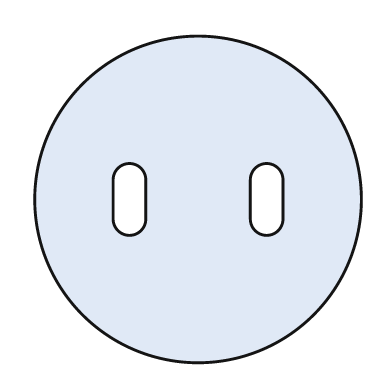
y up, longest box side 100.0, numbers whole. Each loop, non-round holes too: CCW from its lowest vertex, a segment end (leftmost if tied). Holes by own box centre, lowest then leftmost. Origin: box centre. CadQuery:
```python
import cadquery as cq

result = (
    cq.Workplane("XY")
    .moveTo(0.0, 0.0)
    .circle(50.0)
    .moveTo(-26.0, -6.0)
    .threePointArc((-21.0, -11.0), (-16.0, -6.0))
    .lineTo(-16.0, 6.0)
    .threePointArc((-21.0, 11.0), (-26.0, 6.0))
    .close()
    .moveTo(16.0, -6.0)
    .threePointArc((21.0, -11.0), (26.0, -6.0))
    .lineTo(26.0, 6.0)
    .threePointArc((21.0, 11.0), (16.0, 6.0))
    .close()
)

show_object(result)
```